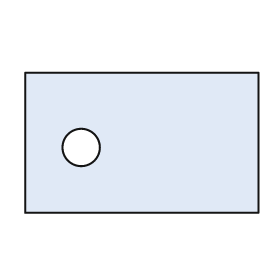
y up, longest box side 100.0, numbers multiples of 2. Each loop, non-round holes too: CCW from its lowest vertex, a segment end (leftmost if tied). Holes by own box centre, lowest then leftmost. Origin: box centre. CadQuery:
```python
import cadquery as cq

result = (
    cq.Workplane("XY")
    .moveTo(-50.0, -30.0)
    .lineTo(50.0, -30.0)
    .lineTo(50.0, 30.0)
    .lineTo(-50.0, 30.0)
    .close()
    .moveTo(-26.0, -2.0)
    .circle(8.0)
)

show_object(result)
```